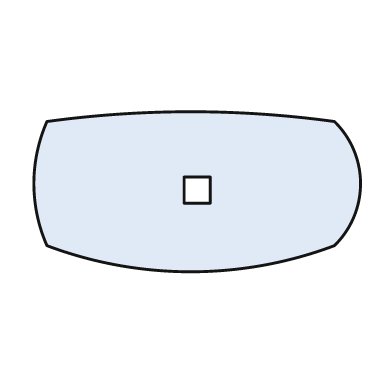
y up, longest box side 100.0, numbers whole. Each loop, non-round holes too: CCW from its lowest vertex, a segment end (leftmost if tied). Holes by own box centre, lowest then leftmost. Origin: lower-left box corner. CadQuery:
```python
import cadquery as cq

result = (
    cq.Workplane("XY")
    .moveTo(4.0, 8.0)
    .threePointArc((48.0, 0.0), (92.0, 8.0))
    .threePointArc((100.0, 27.0), (92.0, 46.0))
    .threePointArc((48.0, 49.0), (4.0, 46.0))
    .threePointArc((0.0, 27.0), (4.0, 8.0))
    .close()
    .moveTo(46.0, 21.0)
    .lineTo(54.0, 21.0)
    .lineTo(54.0, 29.0)
    .lineTo(46.0, 29.0)
    .close()
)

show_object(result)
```